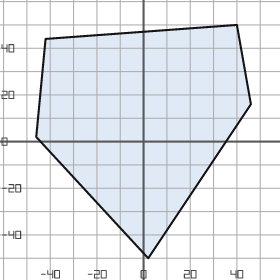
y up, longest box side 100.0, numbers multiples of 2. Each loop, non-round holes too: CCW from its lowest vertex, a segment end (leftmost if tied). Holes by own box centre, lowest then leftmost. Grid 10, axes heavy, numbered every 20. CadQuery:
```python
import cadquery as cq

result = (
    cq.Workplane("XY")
    .moveTo(2.0, -50.0)
    .lineTo(46.0, 16.0)
    .lineTo(40.0, 50.0)
    .lineTo(-42.0, 44.0)
    .lineTo(-46.0, 2.0)
    .close()
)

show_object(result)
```